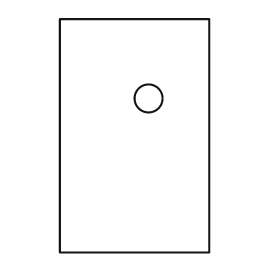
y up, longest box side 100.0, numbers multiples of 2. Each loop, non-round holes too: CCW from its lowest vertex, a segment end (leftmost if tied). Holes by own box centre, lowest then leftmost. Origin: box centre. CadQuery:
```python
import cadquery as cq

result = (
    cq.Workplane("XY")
    .moveTo(-32.0, -50.0)
    .lineTo(32.0, -50.0)
    .lineTo(32.0, 50.0)
    .lineTo(-32.0, 50.0)
    .close()
    .moveTo(6.0, 16.0)
    .circle(6.0)
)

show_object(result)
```